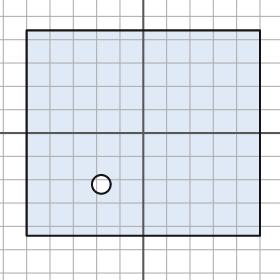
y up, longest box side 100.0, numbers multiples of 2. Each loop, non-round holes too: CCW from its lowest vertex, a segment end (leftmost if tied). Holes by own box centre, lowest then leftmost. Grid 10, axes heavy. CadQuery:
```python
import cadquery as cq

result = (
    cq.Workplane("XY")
    .moveTo(-50.0, -44.0)
    .lineTo(50.0, -44.0)
    .lineTo(50.0, 44.0)
    .lineTo(-50.0, 44.0)
    .close()
    .moveTo(-18.0, -22.0)
    .circle(4.0)
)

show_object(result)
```